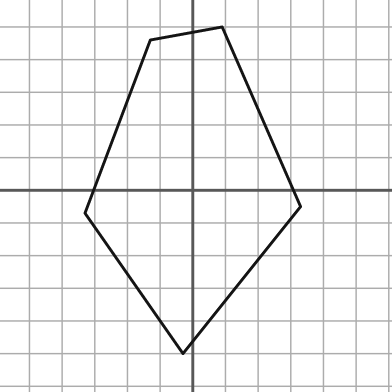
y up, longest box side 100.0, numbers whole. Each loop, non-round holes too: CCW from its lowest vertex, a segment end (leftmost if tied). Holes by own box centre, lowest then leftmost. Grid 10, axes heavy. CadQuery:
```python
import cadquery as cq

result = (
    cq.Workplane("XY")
    .moveTo(-3.0, -50.0)
    .lineTo(33.0, -5.0)
    .lineTo(9.0, 50.0)
    .lineTo(-13.0, 46.0)
    .lineTo(-33.0, -7.0)
    .close()
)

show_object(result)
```